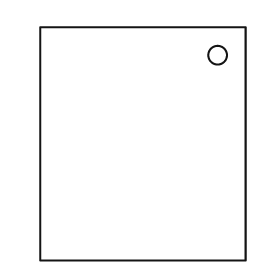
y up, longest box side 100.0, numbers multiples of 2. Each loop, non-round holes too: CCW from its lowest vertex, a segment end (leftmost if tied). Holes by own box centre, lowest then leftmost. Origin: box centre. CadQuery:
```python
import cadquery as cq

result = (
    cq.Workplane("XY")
    .moveTo(-44.0, -50.0)
    .lineTo(44.0, -50.0)
    .lineTo(44.0, 50.0)
    .lineTo(-44.0, 50.0)
    .close()
    .moveTo(32.0, 38.0)
    .circle(4.0)
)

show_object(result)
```